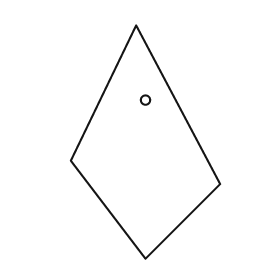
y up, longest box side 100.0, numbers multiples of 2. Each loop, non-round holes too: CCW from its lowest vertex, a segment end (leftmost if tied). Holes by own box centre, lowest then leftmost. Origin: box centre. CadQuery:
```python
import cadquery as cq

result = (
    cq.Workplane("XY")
    .moveTo(0.0, -50.0)
    .lineTo(32.0, -18.0)
    .lineTo(-4.0, 50.0)
    .lineTo(-32.0, -8.0)
    .close()
    .moveTo(0.0, 18.0)
    .circle(2.0)
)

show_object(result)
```